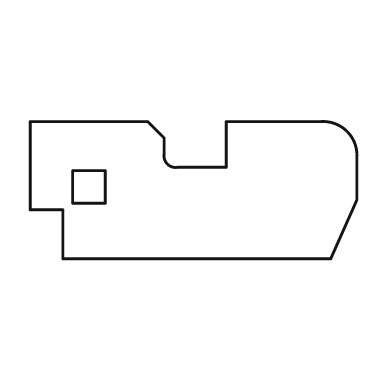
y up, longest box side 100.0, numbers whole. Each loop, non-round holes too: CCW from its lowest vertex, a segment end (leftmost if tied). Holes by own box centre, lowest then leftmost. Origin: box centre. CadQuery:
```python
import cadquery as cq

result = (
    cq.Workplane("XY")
    .moveTo(-40.0, -21.0)
    .lineTo(42.0, -21.0)
    .lineTo(50.0, -3.0)
    .lineTo(50.0, 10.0)
    .threePointArc((47.0, 18.0), (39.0, 21.0))
    .lineTo(10.0, 21.0)
    .lineTo(10.0, 7.0)
    .lineTo(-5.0, 7.0)
    .threePointArc((-8.0, 8.0), (-9.0, 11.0))
    .lineTo(-9.0, 16.0)
    .lineTo(-14.0, 21.0)
    .lineTo(-50.0, 21.0)
    .lineTo(-50.0, -6.0)
    .lineTo(-40.0, -6.0)
    .close()
    .moveTo(-37.0, -4.0)
    .lineTo(-27.0, -4.0)
    .lineTo(-27.0, 6.0)
    .lineTo(-37.0, 6.0)
    .close()
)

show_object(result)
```